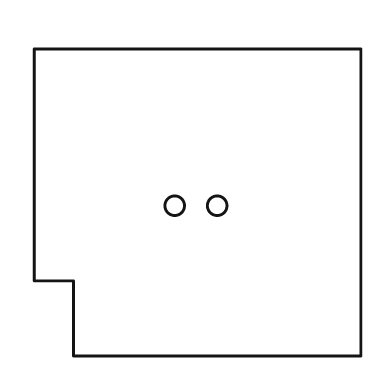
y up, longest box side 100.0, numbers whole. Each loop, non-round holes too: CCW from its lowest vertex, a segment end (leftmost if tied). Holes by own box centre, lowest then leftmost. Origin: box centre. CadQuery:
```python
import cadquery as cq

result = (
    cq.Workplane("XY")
    .moveTo(-38.0, -47.0)
    .lineTo(50.0, -47.0)
    .lineTo(50.0, 47.0)
    .lineTo(-50.0, 47.0)
    .lineTo(-50.0, -24.0)
    .lineTo(-38.0, -24.0)
    .close()
    .moveTo(-7.0, -1.0)
    .circle(3.0)
    .moveTo(6.0, -1.0)
    .circle(3.0)
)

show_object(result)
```